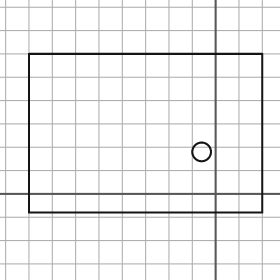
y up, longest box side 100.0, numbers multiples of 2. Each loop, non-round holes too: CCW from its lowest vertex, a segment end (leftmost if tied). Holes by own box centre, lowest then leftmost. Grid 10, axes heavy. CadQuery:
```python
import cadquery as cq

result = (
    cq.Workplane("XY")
    .moveTo(-80.0, -8.0)
    .lineTo(20.0, -8.0)
    .lineTo(20.0, 60.0)
    .lineTo(-80.0, 60.0)
    .close()
    .moveTo(-6.0, 18.0)
    .circle(4.0)
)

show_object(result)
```